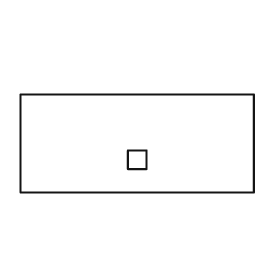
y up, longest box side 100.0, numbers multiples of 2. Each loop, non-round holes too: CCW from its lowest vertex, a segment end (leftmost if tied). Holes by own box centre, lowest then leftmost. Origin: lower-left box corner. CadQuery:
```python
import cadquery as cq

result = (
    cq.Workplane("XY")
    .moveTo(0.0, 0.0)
    .lineTo(100.0, 0.0)
    .lineTo(100.0, 42.0)
    .lineTo(0.0, 42.0)
    .close()
    .moveTo(46.0, 10.0)
    .lineTo(54.0, 10.0)
    .lineTo(54.0, 18.0)
    .lineTo(46.0, 18.0)
    .close()
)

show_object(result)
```